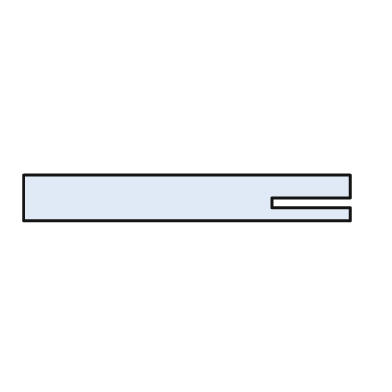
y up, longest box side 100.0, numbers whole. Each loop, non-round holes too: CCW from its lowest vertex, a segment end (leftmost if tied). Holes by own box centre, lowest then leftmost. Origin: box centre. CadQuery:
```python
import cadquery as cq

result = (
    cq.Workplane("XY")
    .moveTo(-50.0, -7.0)
    .lineTo(50.0, -7.0)
    .lineTo(50.0, -3.0)
    .lineTo(26.0, -3.0)
    .lineTo(26.0, 0.0)
    .lineTo(50.0, 0.0)
    .lineTo(50.0, 7.0)
    .lineTo(-50.0, 7.0)
    .close()
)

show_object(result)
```